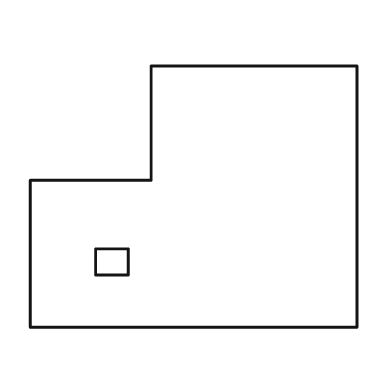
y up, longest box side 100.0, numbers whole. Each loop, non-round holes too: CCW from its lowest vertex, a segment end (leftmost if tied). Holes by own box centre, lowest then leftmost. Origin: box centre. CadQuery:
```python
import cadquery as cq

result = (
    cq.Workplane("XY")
    .moveTo(-50.0, -40.0)
    .lineTo(50.0, -40.0)
    .lineTo(50.0, 40.0)
    .lineTo(-13.0, 40.0)
    .lineTo(-13.0, 5.0)
    .lineTo(-50.0, 5.0)
    .close()
    .moveTo(-30.0, -24.0)
    .lineTo(-20.0, -24.0)
    .lineTo(-20.0, -16.0)
    .lineTo(-30.0, -16.0)
    .close()
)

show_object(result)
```